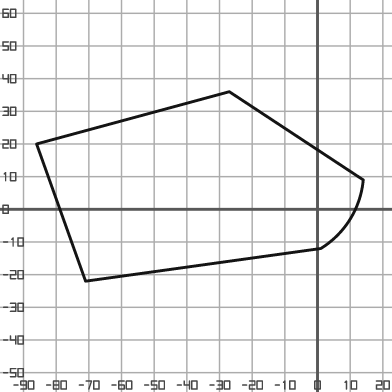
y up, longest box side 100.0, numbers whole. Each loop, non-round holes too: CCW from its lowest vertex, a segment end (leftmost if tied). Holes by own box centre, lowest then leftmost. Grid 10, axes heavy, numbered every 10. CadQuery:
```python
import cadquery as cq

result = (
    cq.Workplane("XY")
    .moveTo(-71.0, -22.0)
    .lineTo(1.0, -12.0)
    .threePointArc((10.0, -3.0), (14.0, 9.0))
    .lineTo(-27.0, 36.0)
    .lineTo(-86.0, 20.0)
    .close()
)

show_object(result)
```